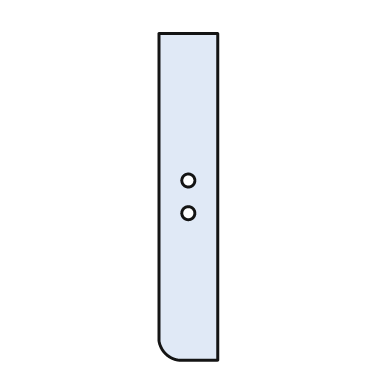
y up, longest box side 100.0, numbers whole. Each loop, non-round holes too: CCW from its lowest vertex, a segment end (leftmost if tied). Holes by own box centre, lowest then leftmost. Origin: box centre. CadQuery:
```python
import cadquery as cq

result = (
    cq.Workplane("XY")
    .moveTo(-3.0, -50.0)
    .lineTo(9.0, -50.0)
    .lineTo(9.0, 50.0)
    .lineTo(-9.0, 50.0)
    .lineTo(-9.0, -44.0)
    .threePointArc((-7.0, -48.0), (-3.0, -50.0))
    .close()
    .moveTo(0.0, -5.0)
    .circle(2.0)
    .moveTo(0.0, 5.0)
    .circle(2.0)
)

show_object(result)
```